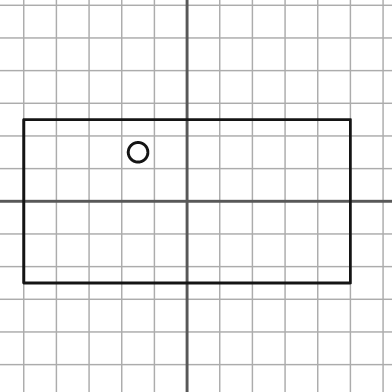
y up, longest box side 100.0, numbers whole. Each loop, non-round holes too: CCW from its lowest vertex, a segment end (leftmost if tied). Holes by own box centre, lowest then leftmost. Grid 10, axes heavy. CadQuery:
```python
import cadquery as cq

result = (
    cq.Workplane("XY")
    .moveTo(-50.0, -25.0)
    .lineTo(50.0, -25.0)
    .lineTo(50.0, 25.0)
    .lineTo(-50.0, 25.0)
    .close()
    .moveTo(-15.0, 15.0)
    .circle(3.0)
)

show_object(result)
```